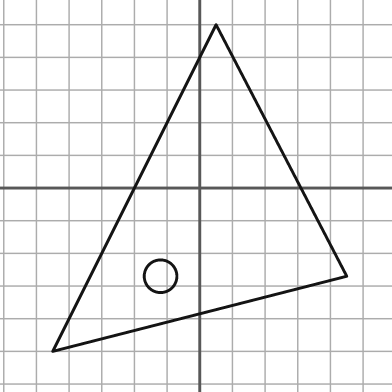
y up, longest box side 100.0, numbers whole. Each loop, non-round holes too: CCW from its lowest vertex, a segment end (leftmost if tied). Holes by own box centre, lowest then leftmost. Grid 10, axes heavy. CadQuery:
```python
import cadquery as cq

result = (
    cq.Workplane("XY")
    .moveTo(-45.0, -50.0)
    .lineTo(45.0, -27.0)
    .lineTo(5.0, 50.0)
    .close()
    .moveTo(-12.0, -27.0)
    .circle(5.0)
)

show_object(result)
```